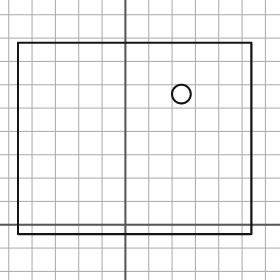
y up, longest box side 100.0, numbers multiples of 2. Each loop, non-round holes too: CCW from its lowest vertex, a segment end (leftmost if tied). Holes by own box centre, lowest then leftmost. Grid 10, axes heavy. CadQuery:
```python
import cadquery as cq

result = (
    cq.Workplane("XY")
    .moveTo(-46.0, -4.0)
    .lineTo(54.0, -4.0)
    .lineTo(54.0, 78.0)
    .lineTo(-46.0, 78.0)
    .close()
    .moveTo(24.0, 56.0)
    .circle(4.0)
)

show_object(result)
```